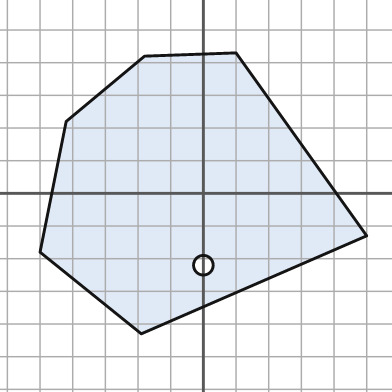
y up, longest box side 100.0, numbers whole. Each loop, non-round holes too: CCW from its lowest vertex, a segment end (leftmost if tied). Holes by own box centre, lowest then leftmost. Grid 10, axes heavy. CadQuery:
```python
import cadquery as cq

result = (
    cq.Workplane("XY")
    .moveTo(-19.0, -43.0)
    .lineTo(50.0, -13.0)
    .lineTo(10.0, 43.0)
    .lineTo(-18.0, 42.0)
    .lineTo(-42.0, 22.0)
    .lineTo(-50.0, -18.0)
    .close()
    .moveTo(0.0, -22.0)
    .circle(3.0)
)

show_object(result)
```